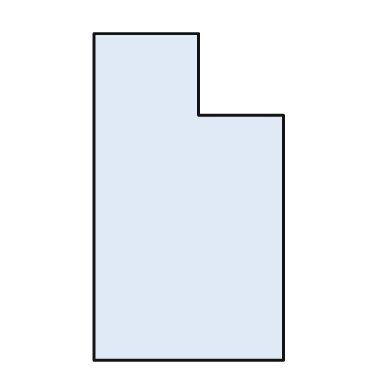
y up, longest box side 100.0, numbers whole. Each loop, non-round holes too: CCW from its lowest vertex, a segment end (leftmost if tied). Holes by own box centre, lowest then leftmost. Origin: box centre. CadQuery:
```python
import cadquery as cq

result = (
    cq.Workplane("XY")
    .moveTo(-29.0, -50.0)
    .lineTo(29.0, -50.0)
    .lineTo(29.0, 25.0)
    .lineTo(3.0, 25.0)
    .lineTo(3.0, 50.0)
    .lineTo(-29.0, 50.0)
    .close()
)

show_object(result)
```